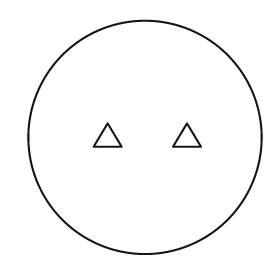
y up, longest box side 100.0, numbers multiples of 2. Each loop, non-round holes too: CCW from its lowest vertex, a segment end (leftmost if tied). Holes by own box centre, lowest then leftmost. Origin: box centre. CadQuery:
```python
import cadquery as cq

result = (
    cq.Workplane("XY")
    .moveTo(0.0, 0.0)
    .circle(50.0)
    .moveTo(-22.0, -4.0)
    .lineTo(-10.0, -4.0)
    .lineTo(-16.0, 6.0)
    .close()
    .moveTo(12.0, -4.0)
    .lineTo(24.0, -4.0)
    .lineTo(18.0, 6.0)
    .close()
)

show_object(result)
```